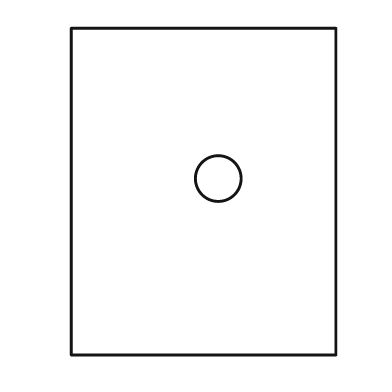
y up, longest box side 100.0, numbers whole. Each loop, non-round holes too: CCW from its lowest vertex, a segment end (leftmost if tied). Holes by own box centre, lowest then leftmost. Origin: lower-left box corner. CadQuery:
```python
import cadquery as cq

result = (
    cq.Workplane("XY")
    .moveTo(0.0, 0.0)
    .lineTo(81.0, 0.0)
    .lineTo(81.0, 100.0)
    .lineTo(0.0, 100.0)
    .close()
    .moveTo(45.0, 54.0)
    .circle(7.0)
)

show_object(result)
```